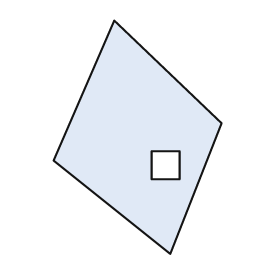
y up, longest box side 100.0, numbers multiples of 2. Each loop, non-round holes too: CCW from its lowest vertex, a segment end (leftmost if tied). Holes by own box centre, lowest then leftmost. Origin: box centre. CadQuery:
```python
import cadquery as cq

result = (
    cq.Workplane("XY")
    .moveTo(14.0, -50.0)
    .lineTo(36.0, 6.0)
    .lineTo(-10.0, 50.0)
    .lineTo(-36.0, -10.0)
    .close()
    .moveTo(6.0, -18.0)
    .lineTo(18.0, -18.0)
    .lineTo(18.0, -6.0)
    .lineTo(6.0, -6.0)
    .close()
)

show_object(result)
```